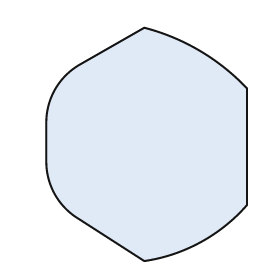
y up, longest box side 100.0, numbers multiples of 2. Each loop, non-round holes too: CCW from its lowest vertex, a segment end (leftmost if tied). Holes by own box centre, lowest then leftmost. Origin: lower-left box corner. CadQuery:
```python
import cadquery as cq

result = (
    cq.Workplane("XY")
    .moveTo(42.0, 0.0)
    .threePointArc((66.0, 8.0), (86.0, 24.0))
    .lineTo(86.0, 74.0)
    .threePointArc((66.0, 90.0), (42.0, 100.0))
    .lineTo(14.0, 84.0)
    .threePointArc((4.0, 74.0), (0.0, 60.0))
    .lineTo(0.0, 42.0)
    .threePointArc((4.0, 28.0), (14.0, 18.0))
    .close()
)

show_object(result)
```